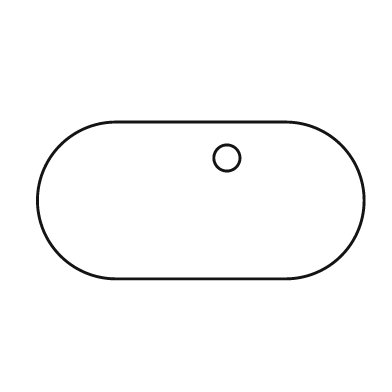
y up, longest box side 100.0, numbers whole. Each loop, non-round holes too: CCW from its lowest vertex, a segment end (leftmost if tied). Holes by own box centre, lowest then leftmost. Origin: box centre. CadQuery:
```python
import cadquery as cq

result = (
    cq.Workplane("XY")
    .moveTo(-26.0, -24.0)
    .lineTo(26.0, -24.0)
    .threePointArc((50.0, 0.0), (26.0, 24.0))
    .lineTo(-26.0, 24.0)
    .threePointArc((-50.0, 0.0), (-26.0, -24.0))
    .close()
    .moveTo(8.0, 13.0)
    .circle(4.0)
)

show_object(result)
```